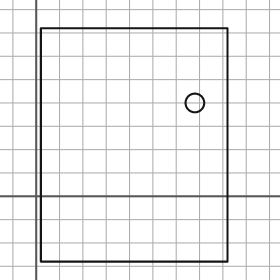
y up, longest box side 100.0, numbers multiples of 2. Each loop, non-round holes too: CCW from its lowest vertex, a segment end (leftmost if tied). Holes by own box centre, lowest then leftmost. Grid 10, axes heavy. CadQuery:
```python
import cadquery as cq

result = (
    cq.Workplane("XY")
    .moveTo(2.0, -28.0)
    .lineTo(82.0, -28.0)
    .lineTo(82.0, 72.0)
    .lineTo(2.0, 72.0)
    .close()
    .moveTo(68.0, 40.0)
    .circle(4.0)
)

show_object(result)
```